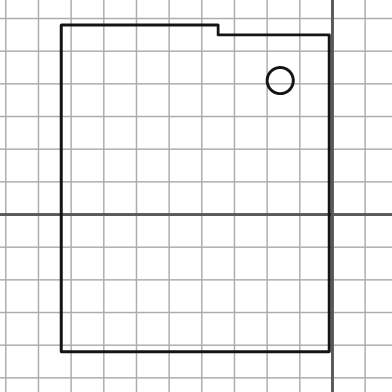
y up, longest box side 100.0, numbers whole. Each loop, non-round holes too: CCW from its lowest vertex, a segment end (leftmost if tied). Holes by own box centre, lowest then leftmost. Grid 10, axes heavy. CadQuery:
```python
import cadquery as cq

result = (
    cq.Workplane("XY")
    .moveTo(-83.0, -42.0)
    .lineTo(-1.0, -42.0)
    .lineTo(-1.0, 55.0)
    .lineTo(-35.0, 55.0)
    .lineTo(-35.0, 58.0)
    .lineTo(-83.0, 58.0)
    .close()
    .moveTo(-16.0, 41.0)
    .circle(4.0)
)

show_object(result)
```